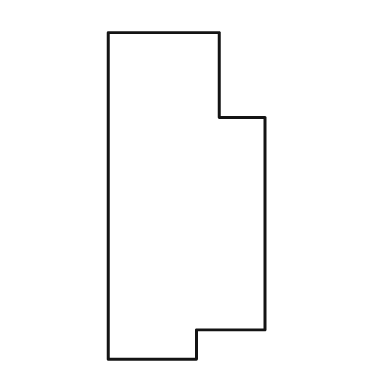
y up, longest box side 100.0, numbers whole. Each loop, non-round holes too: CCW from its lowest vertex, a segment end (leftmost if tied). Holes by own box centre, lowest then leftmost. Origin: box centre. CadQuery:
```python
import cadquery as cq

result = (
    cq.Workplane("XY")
    .moveTo(-24.0, -50.0)
    .lineTo(3.0, -50.0)
    .lineTo(3.0, -41.0)
    .lineTo(24.0, -41.0)
    .lineTo(24.0, 24.0)
    .lineTo(10.0, 24.0)
    .lineTo(10.0, 50.0)
    .lineTo(-24.0, 50.0)
    .close()
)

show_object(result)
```